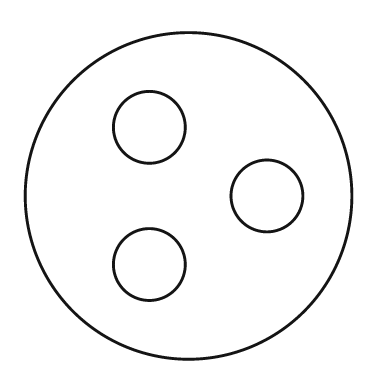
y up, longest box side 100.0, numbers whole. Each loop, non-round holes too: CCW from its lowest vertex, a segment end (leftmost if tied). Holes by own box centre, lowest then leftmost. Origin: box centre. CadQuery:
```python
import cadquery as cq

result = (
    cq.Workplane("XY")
    .moveTo(0.0, 0.0)
    .circle(50.0)
    .moveTo(-12.0, -21.0)
    .circle(11.0)
    .moveTo(24.0, 0.0)
    .circle(11.0)
    .moveTo(-12.0, 21.0)
    .circle(11.0)
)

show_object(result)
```